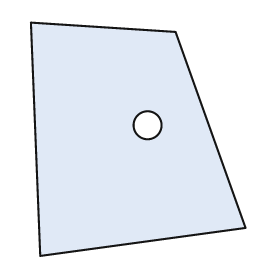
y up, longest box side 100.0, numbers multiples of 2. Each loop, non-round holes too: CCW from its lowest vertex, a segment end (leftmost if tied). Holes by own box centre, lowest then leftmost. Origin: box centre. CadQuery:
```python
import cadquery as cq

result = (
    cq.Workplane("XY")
    .moveTo(-42.0, -50.0)
    .lineTo(46.0, -38.0)
    .lineTo(16.0, 46.0)
    .lineTo(-46.0, 50.0)
    .close()
    .moveTo(4.0, 6.0)
    .circle(6.0)
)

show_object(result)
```